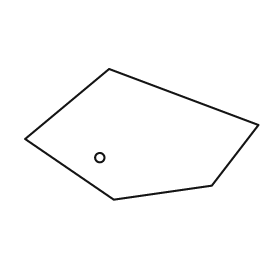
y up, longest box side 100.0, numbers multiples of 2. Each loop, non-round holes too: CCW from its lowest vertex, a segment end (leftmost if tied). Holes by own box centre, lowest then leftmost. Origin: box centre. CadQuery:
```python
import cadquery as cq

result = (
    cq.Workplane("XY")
    .moveTo(-12.0, -28.0)
    .lineTo(30.0, -22.0)
    .lineTo(50.0, 4.0)
    .lineTo(-14.0, 28.0)
    .lineTo(-50.0, -2.0)
    .close()
    .moveTo(-18.0, -10.0)
    .circle(2.0)
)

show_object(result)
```